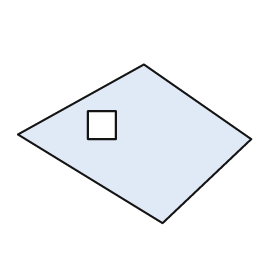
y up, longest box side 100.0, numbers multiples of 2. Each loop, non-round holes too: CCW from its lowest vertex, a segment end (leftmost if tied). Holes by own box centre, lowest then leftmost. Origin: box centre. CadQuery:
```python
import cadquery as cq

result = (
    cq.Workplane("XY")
    .moveTo(12.0, -34.0)
    .lineTo(50.0, 2.0)
    .lineTo(4.0, 34.0)
    .lineTo(-50.0, 4.0)
    .close()
    .moveTo(-20.0, 2.0)
    .lineTo(-8.0, 2.0)
    .lineTo(-8.0, 14.0)
    .lineTo(-20.0, 14.0)
    .close()
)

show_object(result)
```